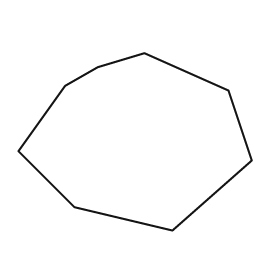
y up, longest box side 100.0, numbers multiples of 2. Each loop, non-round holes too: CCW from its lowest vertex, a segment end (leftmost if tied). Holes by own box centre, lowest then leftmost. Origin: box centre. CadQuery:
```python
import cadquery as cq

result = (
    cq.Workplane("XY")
    .moveTo(16.0, -38.0)
    .lineTo(50.0, -8.0)
    .lineTo(40.0, 22.0)
    .lineTo(4.0, 38.0)
    .lineTo(-16.0, 32.0)
    .lineTo(-30.0, 24.0)
    .lineTo(-50.0, -4.0)
    .lineTo(-26.0, -28.0)
    .close()
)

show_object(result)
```